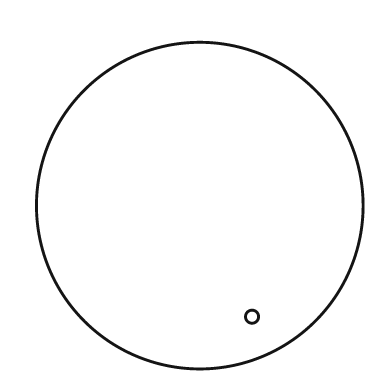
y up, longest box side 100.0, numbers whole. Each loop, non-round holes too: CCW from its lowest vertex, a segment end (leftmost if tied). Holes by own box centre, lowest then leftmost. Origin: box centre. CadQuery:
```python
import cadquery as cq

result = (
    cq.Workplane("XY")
    .moveTo(0.0, 0.0)
    .circle(50.0)
    .moveTo(16.0, -34.0)
    .circle(2.0)
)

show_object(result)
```